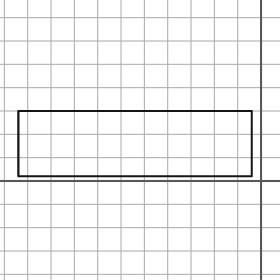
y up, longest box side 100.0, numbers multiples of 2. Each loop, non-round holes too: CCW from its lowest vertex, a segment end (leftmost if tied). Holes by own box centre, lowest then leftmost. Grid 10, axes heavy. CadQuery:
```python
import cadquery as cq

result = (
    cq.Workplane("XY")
    .moveTo(-104.0, 2.0)
    .lineTo(-4.0, 2.0)
    .lineTo(-4.0, 30.0)
    .lineTo(-104.0, 30.0)
    .close()
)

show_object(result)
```